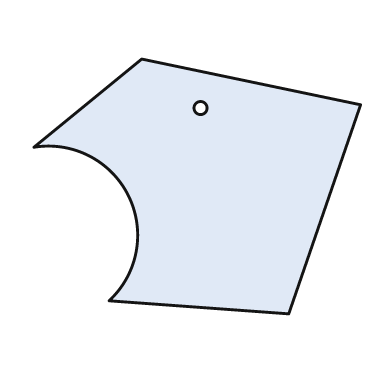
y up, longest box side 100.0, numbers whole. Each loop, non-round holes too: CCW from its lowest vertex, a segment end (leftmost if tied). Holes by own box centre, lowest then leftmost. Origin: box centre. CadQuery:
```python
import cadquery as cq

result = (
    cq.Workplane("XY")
    .moveTo(28.0, -39.0)
    .lineTo(50.0, 25.0)
    .lineTo(-17.0, 39.0)
    .lineTo(-50.0, 12.0)
    .threePointArc((-21.0, -3.0), (-27.0, -35.0))
    .close()
    .moveTo(1.0, 24.0)
    .circle(2.0)
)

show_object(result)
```